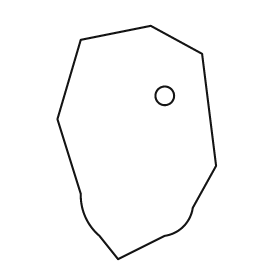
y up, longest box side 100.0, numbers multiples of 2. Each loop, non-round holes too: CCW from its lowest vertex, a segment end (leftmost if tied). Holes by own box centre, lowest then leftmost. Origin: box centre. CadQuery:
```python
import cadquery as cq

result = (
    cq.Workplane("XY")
    .moveTo(-8.0, -50.0)
    .lineTo(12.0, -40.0)
    .threePointArc((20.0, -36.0), (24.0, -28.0))
    .lineTo(34.0, -10.0)
    .lineTo(28.0, 38.0)
    .lineTo(6.0, 50.0)
    .lineTo(-24.0, 44.0)
    .lineTo(-34.0, 10.0)
    .lineTo(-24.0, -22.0)
    .threePointArc((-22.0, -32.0), (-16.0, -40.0))
    .close()
    .moveTo(12.0, 20.0)
    .circle(4.0)
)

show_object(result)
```